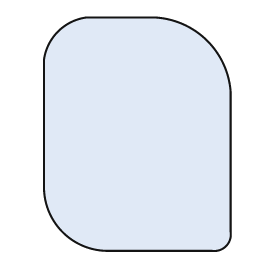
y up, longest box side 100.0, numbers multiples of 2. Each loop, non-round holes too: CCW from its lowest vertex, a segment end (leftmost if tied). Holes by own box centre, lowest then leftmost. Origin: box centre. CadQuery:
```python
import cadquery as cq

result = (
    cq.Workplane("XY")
    .moveTo(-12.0, -50.0)
    .lineTo(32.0, -50.0)
    .threePointArc((38.0, -48.0), (40.0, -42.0))
    .lineTo(40.0, 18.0)
    .threePointArc((30.0, 40.0), (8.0, 50.0))
    .lineTo(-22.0, 50.0)
    .threePointArc((-34.0, 44.0), (-40.0, 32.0))
    .lineTo(-40.0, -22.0)
    .threePointArc((-32.0, -42.0), (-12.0, -50.0))
    .close()
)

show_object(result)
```